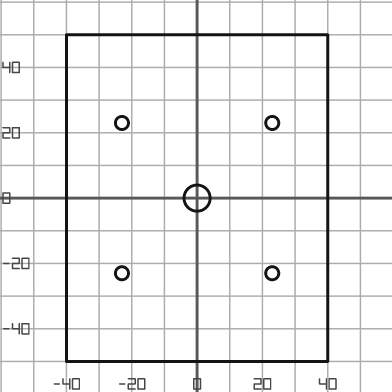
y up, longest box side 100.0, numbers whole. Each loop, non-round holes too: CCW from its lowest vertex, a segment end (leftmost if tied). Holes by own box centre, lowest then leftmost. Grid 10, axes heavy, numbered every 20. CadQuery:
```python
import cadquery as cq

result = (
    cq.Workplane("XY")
    .moveTo(-40.0, -50.0)
    .lineTo(40.0, -50.0)
    .lineTo(40.0, 50.0)
    .lineTo(-40.0, 50.0)
    .close()
    .moveTo(-23.0, -23.0)
    .circle(2.0)
    .moveTo(23.0, -23.0)
    .circle(2.0)
    .moveTo(0.0, 0.0)
    .circle(4.0)
    .moveTo(-23.0, 23.0)
    .circle(2.0)
    .moveTo(23.0, 23.0)
    .circle(2.0)
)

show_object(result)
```